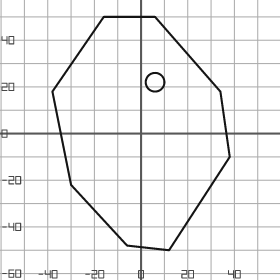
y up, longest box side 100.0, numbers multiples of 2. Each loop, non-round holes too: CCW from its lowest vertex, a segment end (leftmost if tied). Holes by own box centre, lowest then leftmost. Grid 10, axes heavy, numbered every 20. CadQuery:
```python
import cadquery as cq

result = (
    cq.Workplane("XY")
    .moveTo(12.0, -50.0)
    .lineTo(38.0, -10.0)
    .lineTo(34.0, 18.0)
    .lineTo(6.0, 50.0)
    .lineTo(-16.0, 50.0)
    .lineTo(-38.0, 18.0)
    .lineTo(-30.0, -22.0)
    .lineTo(-6.0, -48.0)
    .close()
    .moveTo(6.0, 22.0)
    .circle(4.0)
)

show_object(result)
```